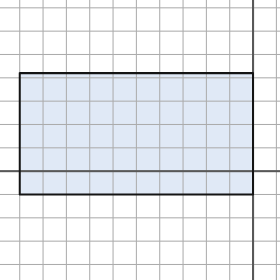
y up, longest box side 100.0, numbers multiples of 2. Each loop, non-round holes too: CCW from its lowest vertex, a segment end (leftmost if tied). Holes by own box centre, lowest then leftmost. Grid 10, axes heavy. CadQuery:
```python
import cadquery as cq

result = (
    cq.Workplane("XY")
    .moveTo(-100.0, -10.0)
    .lineTo(0.0, -10.0)
    .lineTo(0.0, 42.0)
    .lineTo(-100.0, 42.0)
    .close()
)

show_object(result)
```